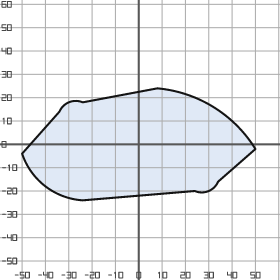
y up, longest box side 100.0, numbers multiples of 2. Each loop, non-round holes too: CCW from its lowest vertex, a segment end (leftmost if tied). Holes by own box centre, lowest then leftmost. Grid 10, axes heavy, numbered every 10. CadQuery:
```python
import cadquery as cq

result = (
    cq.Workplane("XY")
    .moveTo(-24.0, -24.0)
    .lineTo(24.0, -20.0)
    .threePointArc((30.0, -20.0), (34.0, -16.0))
    .lineTo(50.0, -2.0)
    .threePointArc((32.0, 16.0), (8.0, 24.0))
    .lineTo(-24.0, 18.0)
    .threePointArc((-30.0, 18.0), (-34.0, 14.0))
    .lineTo(-50.0, -4.0)
    .threePointArc((-40.0, -18.0), (-24.0, -24.0))
    .close()
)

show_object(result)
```